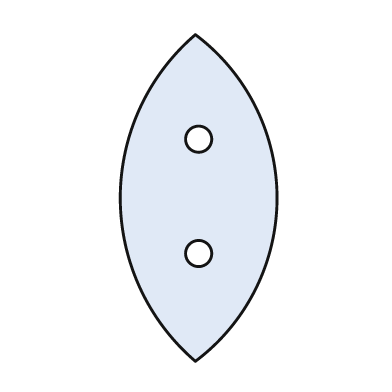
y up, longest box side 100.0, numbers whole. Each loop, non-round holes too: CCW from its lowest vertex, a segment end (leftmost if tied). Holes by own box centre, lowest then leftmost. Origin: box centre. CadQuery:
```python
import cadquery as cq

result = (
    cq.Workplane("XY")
    .moveTo(-1.0, -50.0)
    .threePointArc((24.0, 0.0), (-1.0, 50.0))
    .threePointArc((-24.0, 0.0), (-1.0, -50.0))
    .close()
    .moveTo(0.0, -17.0)
    .circle(4.0)
    .moveTo(0.0, 18.0)
    .circle(4.0)
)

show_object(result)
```